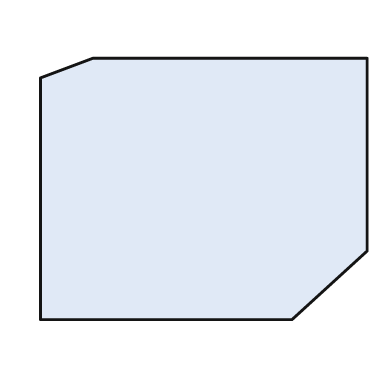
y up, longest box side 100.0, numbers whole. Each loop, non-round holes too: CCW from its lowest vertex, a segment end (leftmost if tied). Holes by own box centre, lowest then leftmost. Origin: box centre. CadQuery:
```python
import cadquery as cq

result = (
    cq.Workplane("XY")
    .moveTo(-50.0, -40.0)
    .lineTo(27.0, -40.0)
    .lineTo(50.0, -19.0)
    .lineTo(50.0, 40.0)
    .lineTo(-34.0, 40.0)
    .lineTo(-50.0, 34.0)
    .close()
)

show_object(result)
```